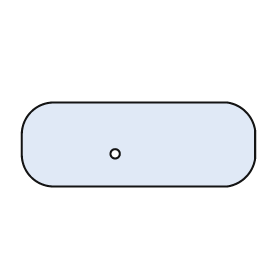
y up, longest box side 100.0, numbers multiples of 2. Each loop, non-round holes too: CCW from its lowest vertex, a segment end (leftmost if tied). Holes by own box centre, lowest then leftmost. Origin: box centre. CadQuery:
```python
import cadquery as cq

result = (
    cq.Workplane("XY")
    .moveTo(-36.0, -18.0)
    .lineTo(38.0, -18.0)
    .threePointArc((46.0, -14.0), (50.0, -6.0))
    .lineTo(50.0, 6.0)
    .threePointArc((46.0, 14.0), (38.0, 18.0))
    .lineTo(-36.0, 18.0)
    .threePointArc((-46.0, 14.0), (-50.0, 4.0))
    .lineTo(-50.0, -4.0)
    .threePointArc((-46.0, -14.0), (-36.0, -18.0))
    .close()
    .moveTo(-10.0, -4.0)
    .circle(2.0)
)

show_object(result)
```